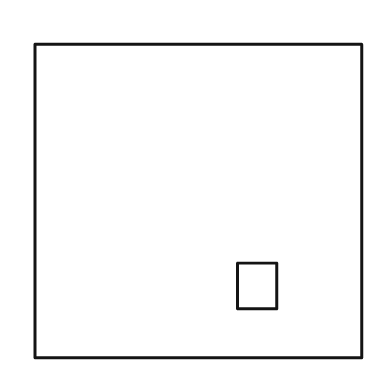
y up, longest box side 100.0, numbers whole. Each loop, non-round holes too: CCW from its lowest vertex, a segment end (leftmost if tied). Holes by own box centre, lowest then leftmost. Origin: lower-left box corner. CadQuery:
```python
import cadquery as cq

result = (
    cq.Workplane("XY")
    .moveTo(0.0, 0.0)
    .lineTo(100.0, 0.0)
    .lineTo(100.0, 96.0)
    .lineTo(0.0, 96.0)
    .close()
    .moveTo(62.0, 15.0)
    .lineTo(74.0, 15.0)
    .lineTo(74.0, 29.0)
    .lineTo(62.0, 29.0)
    .close()
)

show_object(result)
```